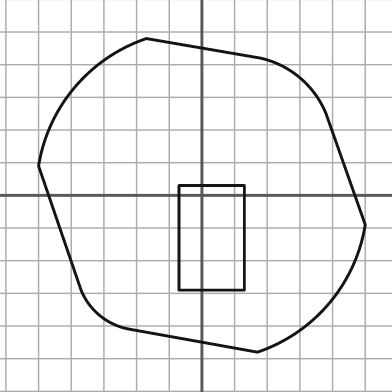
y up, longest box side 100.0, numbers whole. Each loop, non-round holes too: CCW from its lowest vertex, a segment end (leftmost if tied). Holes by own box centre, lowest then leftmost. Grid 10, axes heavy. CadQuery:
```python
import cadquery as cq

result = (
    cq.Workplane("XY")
    .moveTo(17.0, -48.0)
    .threePointArc((39.0, -33.0), (50.0, -9.0))
    .lineTo(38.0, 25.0)
    .threePointArc((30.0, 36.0), (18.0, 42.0))
    .lineTo(-17.0, 48.0)
    .threePointArc((-39.0, 33.0), (-50.0, 9.0))
    .lineTo(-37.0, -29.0)
    .threePointArc((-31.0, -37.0), (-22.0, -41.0))
    .close()
    .moveTo(-7.0, -29.0)
    .lineTo(13.0, -29.0)
    .lineTo(13.0, 3.0)
    .lineTo(-7.0, 3.0)
    .close()
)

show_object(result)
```